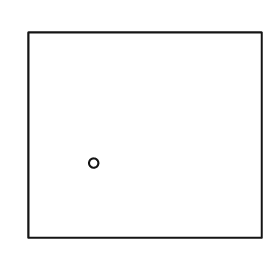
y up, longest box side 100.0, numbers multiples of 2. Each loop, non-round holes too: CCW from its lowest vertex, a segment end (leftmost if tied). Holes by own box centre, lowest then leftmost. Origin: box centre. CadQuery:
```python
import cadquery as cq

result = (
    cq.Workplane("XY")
    .moveTo(-50.0, -44.0)
    .lineTo(50.0, -44.0)
    .lineTo(50.0, 44.0)
    .lineTo(-50.0, 44.0)
    .close()
    .moveTo(-22.0, -12.0)
    .circle(2.0)
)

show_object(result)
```